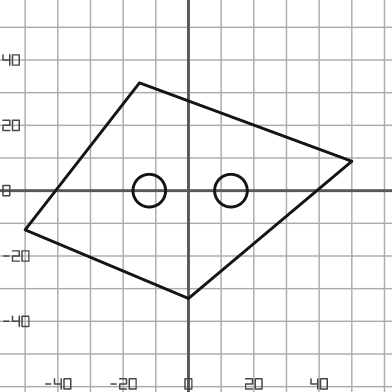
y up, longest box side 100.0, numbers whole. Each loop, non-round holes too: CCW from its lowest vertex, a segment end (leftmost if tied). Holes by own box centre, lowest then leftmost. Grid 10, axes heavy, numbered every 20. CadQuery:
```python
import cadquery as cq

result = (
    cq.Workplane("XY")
    .moveTo(0.0, -33.0)
    .lineTo(50.0, 9.0)
    .lineTo(-15.0, 33.0)
    .lineTo(-50.0, -12.0)
    .close()
    .moveTo(-12.0, 0.0)
    .circle(5.0)
    .moveTo(13.0, 0.0)
    .circle(5.0)
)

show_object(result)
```